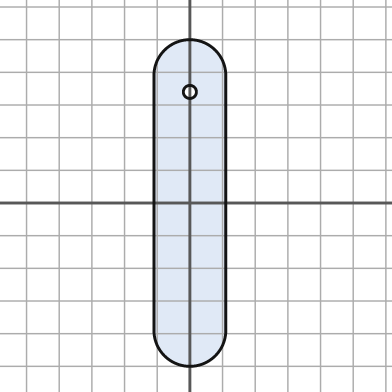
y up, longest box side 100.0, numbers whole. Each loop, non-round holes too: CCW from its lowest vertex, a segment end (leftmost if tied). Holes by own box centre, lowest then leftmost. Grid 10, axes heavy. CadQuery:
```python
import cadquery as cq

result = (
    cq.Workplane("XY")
    .moveTo(-11.0, -39.0)
    .threePointArc((0.0, -50.0), (11.0, -39.0))
    .lineTo(11.0, 39.0)
    .threePointArc((0.0, 50.0), (-11.0, 39.0))
    .close()
    .moveTo(0.0, 34.0)
    .circle(2.0)
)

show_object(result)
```